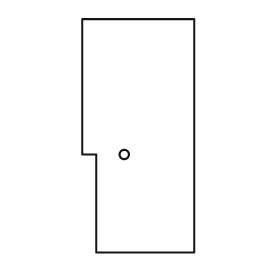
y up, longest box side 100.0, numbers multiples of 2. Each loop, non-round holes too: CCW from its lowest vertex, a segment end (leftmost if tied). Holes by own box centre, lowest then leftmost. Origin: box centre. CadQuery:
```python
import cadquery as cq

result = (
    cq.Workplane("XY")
    .moveTo(-18.0, -50.0)
    .lineTo(24.0, -50.0)
    .lineTo(24.0, 50.0)
    .lineTo(-24.0, 50.0)
    .lineTo(-24.0, -8.0)
    .lineTo(-18.0, -8.0)
    .close()
    .moveTo(-6.0, -8.0)
    .circle(2.0)
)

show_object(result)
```